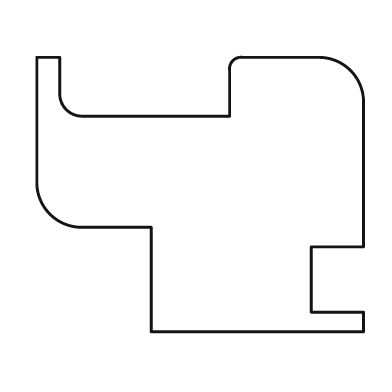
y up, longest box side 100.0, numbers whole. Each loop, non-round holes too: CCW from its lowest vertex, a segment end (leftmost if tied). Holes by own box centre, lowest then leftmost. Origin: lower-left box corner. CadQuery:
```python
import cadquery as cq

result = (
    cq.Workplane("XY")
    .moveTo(35.0, 0.0)
    .lineTo(100.0, 0.0)
    .lineTo(100.0, 6.0)
    .lineTo(84.0, 6.0)
    .lineTo(84.0, 26.0)
    .lineTo(100.0, 26.0)
    .lineTo(100.0, 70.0)
    .threePointArc((96.0, 80.0), (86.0, 84.0))
    .lineTo(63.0, 84.0)
    .threePointArc((60.0, 83.0), (59.0, 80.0))
    .lineTo(59.0, 66.0)
    .lineTo(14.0, 66.0)
    .threePointArc((9.0, 68.0), (7.0, 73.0))
    .lineTo(7.0, 84.0)
    .lineTo(0.0, 84.0)
    .lineTo(0.0, 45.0)
    .threePointArc((4.0, 36.0), (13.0, 32.0))
    .lineTo(35.0, 32.0)
    .close()
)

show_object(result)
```